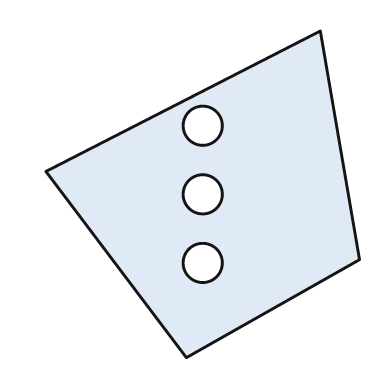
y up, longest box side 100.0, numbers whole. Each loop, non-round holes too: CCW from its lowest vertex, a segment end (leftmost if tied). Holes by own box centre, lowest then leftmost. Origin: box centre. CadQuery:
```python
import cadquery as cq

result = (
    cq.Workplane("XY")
    .moveTo(-5.0, -50.0)
    .lineTo(48.0, -20.0)
    .lineTo(36.0, 50.0)
    .lineTo(-48.0, 7.0)
    .close()
    .moveTo(0.0, -21.0)
    .circle(6.0)
    .moveTo(0.0, 0.0)
    .circle(6.0)
    .moveTo(0.0, 21.0)
    .circle(6.0)
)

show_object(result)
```